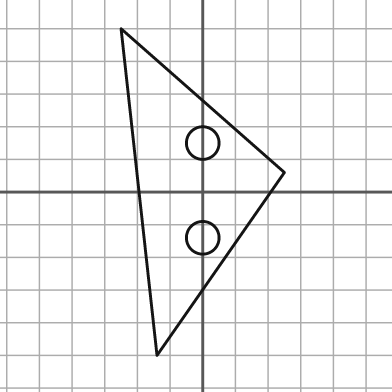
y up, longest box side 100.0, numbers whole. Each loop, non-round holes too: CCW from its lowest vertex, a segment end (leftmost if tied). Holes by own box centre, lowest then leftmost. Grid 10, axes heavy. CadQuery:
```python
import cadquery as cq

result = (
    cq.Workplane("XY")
    .moveTo(-14.0, -50.0)
    .lineTo(25.0, 6.0)
    .lineTo(-25.0, 50.0)
    .close()
    .moveTo(0.0, -14.0)
    .circle(5.0)
    .moveTo(0.0, 15.0)
    .circle(5.0)
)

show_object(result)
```